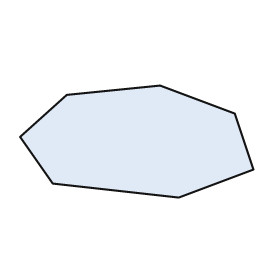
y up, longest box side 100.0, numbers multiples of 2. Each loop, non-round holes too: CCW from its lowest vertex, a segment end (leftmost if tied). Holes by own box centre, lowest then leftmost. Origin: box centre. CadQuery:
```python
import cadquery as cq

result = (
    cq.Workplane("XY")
    .moveTo(18.0, -24.0)
    .lineTo(50.0, -12.0)
    .lineTo(42.0, 12.0)
    .lineTo(10.0, 24.0)
    .lineTo(-30.0, 20.0)
    .lineTo(-50.0, 2.0)
    .lineTo(-36.0, -18.0)
    .close()
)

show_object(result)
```